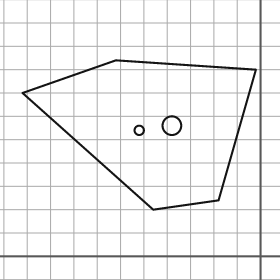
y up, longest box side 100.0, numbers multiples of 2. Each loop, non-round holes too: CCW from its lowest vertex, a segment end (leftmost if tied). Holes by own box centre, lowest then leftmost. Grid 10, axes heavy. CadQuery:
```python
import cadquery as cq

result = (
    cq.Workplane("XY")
    .moveTo(-46.0, 20.0)
    .lineTo(-18.0, 24.0)
    .lineTo(-2.0, 80.0)
    .lineTo(-62.0, 84.0)
    .lineTo(-102.0, 70.0)
    .close()
    .moveTo(-52.0, 54.0)
    .circle(2.0)
    .moveTo(-38.0, 56.0)
    .circle(4.0)
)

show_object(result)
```